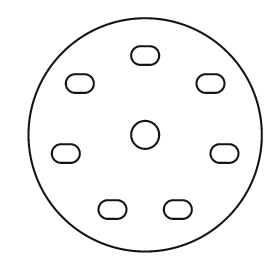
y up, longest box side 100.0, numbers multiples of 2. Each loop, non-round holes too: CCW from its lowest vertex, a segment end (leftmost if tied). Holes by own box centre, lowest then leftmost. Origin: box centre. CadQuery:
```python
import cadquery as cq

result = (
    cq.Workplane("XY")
    .moveTo(0.0, 0.0)
    .circle(50.0)
    .moveTo(-16.0, -36.0)
    .lineTo(-12.0, -36.0)
    .threePointArc((-8.0, -32.0), (-12.0, -28.0))
    .lineTo(-16.0, -28.0)
    .threePointArc((-20.0, -32.0), (-16.0, -36.0))
    .close()
    .moveTo(12.0, -36.0)
    .lineTo(16.0, -36.0)
    .threePointArc((20.0, -32.0), (16.0, -28.0))
    .lineTo(12.0, -28.0)
    .threePointArc((8.0, -32.0), (12.0, -36.0))
    .close()
    .moveTo(-36.0, -12.0)
    .lineTo(-32.0, -12.0)
    .threePointArc((-28.0, -8.0), (-32.0, -4.0))
    .lineTo(-36.0, -4.0)
    .threePointArc((-40.0, -8.0), (-36.0, -12.0))
    .close()
    .moveTo(32.0, -12.0)
    .lineTo(36.0, -12.0)
    .threePointArc((40.0, -8.0), (36.0, -4.0))
    .lineTo(32.0, -4.0)
    .threePointArc((28.0, -8.0), (32.0, -12.0))
    .close()
    .moveTo(0.0, 0.0)
    .circle(6.0)
    .moveTo(-30.0, 18.0)
    .lineTo(-26.0, 18.0)
    .threePointArc((-22.0, 22.0), (-26.0, 26.0))
    .lineTo(-30.0, 26.0)
    .threePointArc((-34.0, 22.0), (-30.0, 18.0))
    .close()
    .moveTo(26.0, 18.0)
    .lineTo(30.0, 18.0)
    .threePointArc((34.0, 22.0), (30.0, 26.0))
    .lineTo(26.0, 26.0)
    .threePointArc((22.0, 22.0), (26.0, 18.0))
    .close()
    .moveTo(-2.0, 30.0)
    .lineTo(2.0, 30.0)
    .threePointArc((6.0, 34.0), (2.0, 38.0))
    .lineTo(-2.0, 38.0)
    .threePointArc((-6.0, 34.0), (-2.0, 30.0))
    .close()
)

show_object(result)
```